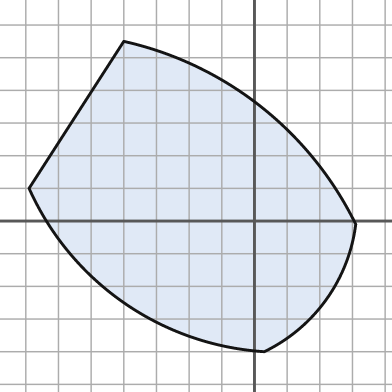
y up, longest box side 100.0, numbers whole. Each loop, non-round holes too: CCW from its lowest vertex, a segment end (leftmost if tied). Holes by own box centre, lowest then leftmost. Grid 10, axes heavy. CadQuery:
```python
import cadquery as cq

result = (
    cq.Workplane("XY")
    .moveTo(3.0, -40.0)
    .threePointArc((22.0, -24.0), (31.0, -1.0))
    .threePointArc((2.0, 35.0), (-40.0, 55.0))
    .lineTo(-69.0, 10.0)
    .threePointArc((-40.0, -25.0), (3.0, -40.0))
    .close()
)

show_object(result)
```